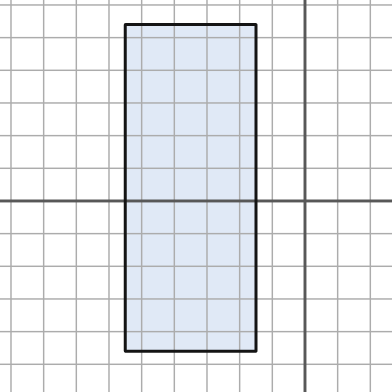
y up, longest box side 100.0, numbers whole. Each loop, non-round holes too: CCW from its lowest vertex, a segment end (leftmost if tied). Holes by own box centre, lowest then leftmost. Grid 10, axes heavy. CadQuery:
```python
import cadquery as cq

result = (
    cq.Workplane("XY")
    .moveTo(-55.0, -46.0)
    .lineTo(-15.0, -46.0)
    .lineTo(-15.0, 54.0)
    .lineTo(-55.0, 54.0)
    .close()
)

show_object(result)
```